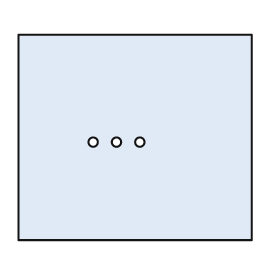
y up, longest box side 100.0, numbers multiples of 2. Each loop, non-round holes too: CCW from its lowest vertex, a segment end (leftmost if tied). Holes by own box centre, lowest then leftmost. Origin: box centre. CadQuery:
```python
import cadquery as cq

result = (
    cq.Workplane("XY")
    .moveTo(-50.0, -44.0)
    .lineTo(50.0, -44.0)
    .lineTo(50.0, 44.0)
    .lineTo(-50.0, 44.0)
    .close()
    .moveTo(-18.0, -2.0)
    .circle(2.0)
    .moveTo(-8.0, -2.0)
    .circle(2.0)
    .moveTo(2.0, -2.0)
    .circle(2.0)
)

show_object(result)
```